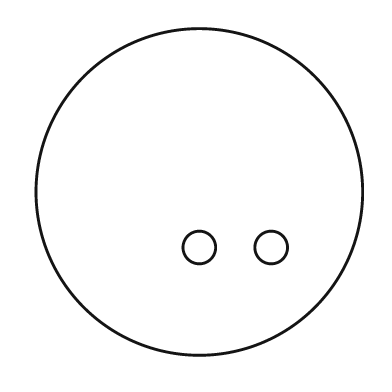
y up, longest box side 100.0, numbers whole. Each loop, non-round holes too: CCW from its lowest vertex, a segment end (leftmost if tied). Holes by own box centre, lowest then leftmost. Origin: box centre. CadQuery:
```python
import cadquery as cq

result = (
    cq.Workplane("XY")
    .moveTo(0.0, 0.0)
    .circle(50.0)
    .moveTo(0.0, -17.0)
    .circle(5.0)
    .moveTo(22.0, -17.0)
    .circle(5.0)
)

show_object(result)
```